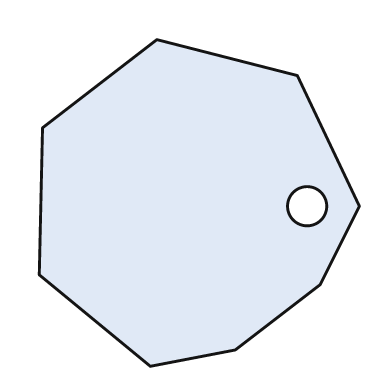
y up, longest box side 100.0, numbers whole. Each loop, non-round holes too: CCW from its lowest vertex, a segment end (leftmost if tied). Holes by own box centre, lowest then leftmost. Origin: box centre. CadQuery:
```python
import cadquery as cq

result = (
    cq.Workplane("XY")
    .moveTo(-15.0, -50.0)
    .lineTo(11.0, -45.0)
    .lineTo(37.0, -25.0)
    .lineTo(49.0, -1.0)
    .lineTo(30.0, 39.0)
    .lineTo(-13.0, 50.0)
    .lineTo(-48.0, 23.0)
    .lineTo(-49.0, -22.0)
    .close()
    .moveTo(33.0, -1.0)
    .circle(6.0)
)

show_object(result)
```